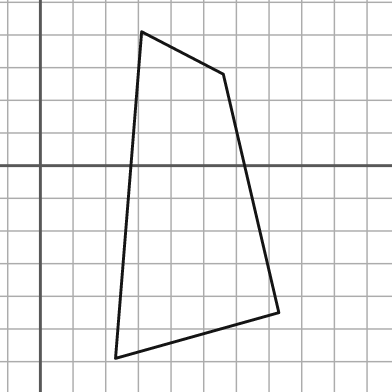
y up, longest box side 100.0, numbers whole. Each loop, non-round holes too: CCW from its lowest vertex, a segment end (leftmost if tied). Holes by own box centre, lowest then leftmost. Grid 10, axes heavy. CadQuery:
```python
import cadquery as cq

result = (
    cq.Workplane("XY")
    .moveTo(23.0, -59.0)
    .lineTo(73.0, -45.0)
    .lineTo(56.0, 28.0)
    .lineTo(31.0, 41.0)
    .close()
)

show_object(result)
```